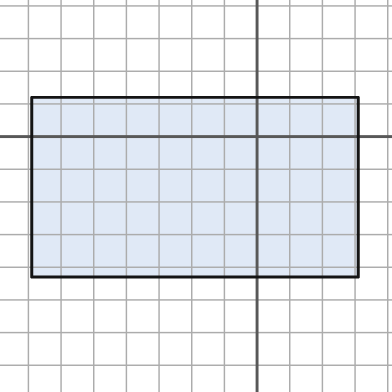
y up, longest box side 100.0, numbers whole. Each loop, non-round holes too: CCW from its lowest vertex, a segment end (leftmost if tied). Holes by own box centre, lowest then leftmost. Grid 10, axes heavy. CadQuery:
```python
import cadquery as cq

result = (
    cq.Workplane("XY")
    .moveTo(-69.0, -43.0)
    .lineTo(31.0, -43.0)
    .lineTo(31.0, 12.0)
    .lineTo(-69.0, 12.0)
    .close()
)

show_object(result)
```